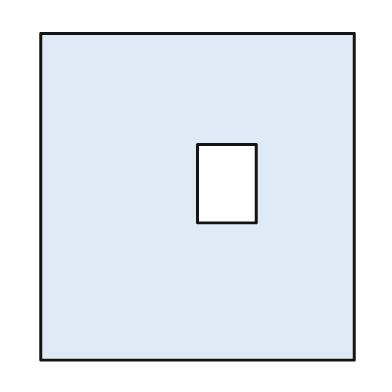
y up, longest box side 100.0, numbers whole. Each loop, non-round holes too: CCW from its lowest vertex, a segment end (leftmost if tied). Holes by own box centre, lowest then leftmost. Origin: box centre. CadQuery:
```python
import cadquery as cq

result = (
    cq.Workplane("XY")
    .moveTo(-48.0, -50.0)
    .lineTo(48.0, -50.0)
    .lineTo(48.0, 50.0)
    .lineTo(-48.0, 50.0)
    .close()
    .moveTo(0.0, -8.0)
    .lineTo(18.0, -8.0)
    .lineTo(18.0, 16.0)
    .lineTo(0.0, 16.0)
    .close()
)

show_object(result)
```